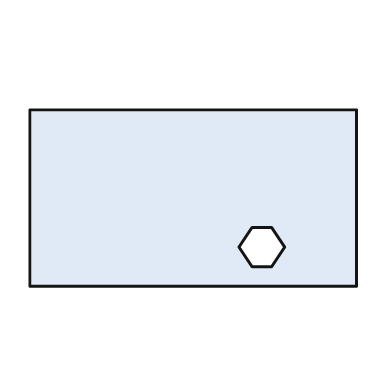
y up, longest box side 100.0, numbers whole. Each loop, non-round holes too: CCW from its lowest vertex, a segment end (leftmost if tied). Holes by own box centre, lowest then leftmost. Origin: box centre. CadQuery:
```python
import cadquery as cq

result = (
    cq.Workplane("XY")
    .moveTo(-50.0, -27.0)
    .lineTo(50.0, -27.0)
    .lineTo(50.0, 27.0)
    .lineTo(-50.0, 27.0)
    .close()
    .moveTo(18.0, -21.0)
    .lineTo(24.0, -21.0)
    .lineTo(28.0, -15.0)
    .lineTo(24.0, -9.0)
    .lineTo(18.0, -9.0)
    .lineTo(14.0, -15.0)
    .close()
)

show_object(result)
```